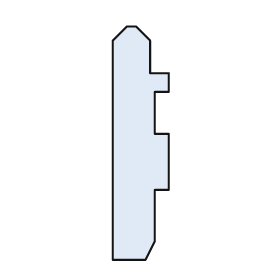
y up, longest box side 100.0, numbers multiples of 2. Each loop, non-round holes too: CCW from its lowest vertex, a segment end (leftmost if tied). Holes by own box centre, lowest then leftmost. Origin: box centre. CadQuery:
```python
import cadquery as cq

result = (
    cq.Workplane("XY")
    .moveTo(-12.0, -50.0)
    .lineTo(2.0, -50.0)
    .lineTo(6.0, -42.0)
    .lineTo(6.0, -20.0)
    .lineTo(12.0, -20.0)
    .lineTo(12.0, 4.0)
    .lineTo(6.0, 4.0)
    .lineTo(6.0, 22.0)
    .lineTo(12.0, 22.0)
    .lineTo(12.0, 30.0)
    .lineTo(4.0, 30.0)
    .lineTo(4.0, 44.0)
    .lineTo(-2.0, 50.0)
    .lineTo(-6.0, 50.0)
    .lineTo(-12.0, 44.0)
    .close()
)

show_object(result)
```